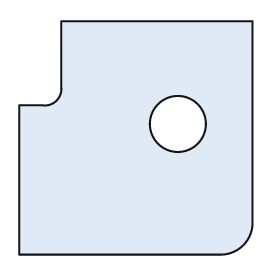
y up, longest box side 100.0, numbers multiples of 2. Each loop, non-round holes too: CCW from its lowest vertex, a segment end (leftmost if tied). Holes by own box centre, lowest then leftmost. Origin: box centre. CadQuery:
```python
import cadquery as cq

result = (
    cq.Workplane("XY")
    .moveTo(-50.0, -50.0)
    .lineTo(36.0, -50.0)
    .threePointArc((46.0, -46.0), (50.0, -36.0))
    .lineTo(50.0, 50.0)
    .lineTo(-32.0, 50.0)
    .lineTo(-32.0, 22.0)
    .threePointArc((-34.0, 16.0), (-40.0, 14.0))
    .lineTo(-50.0, 14.0)
    .close()
    .moveTo(18.0, 6.0)
    .circle(12.0)
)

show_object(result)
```